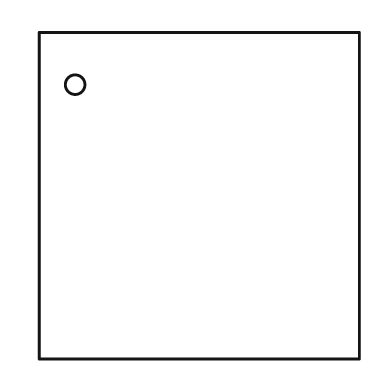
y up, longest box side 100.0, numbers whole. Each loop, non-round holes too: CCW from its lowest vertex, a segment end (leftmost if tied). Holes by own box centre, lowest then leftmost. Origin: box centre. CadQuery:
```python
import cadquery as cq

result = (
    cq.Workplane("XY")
    .moveTo(-49.0, -50.0)
    .lineTo(49.0, -50.0)
    .lineTo(49.0, 50.0)
    .lineTo(-49.0, 50.0)
    .close()
    .moveTo(-38.0, 34.0)
    .circle(3.0)
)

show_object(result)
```